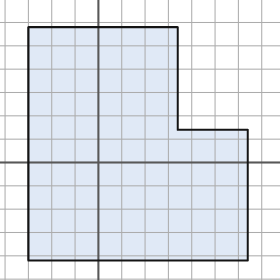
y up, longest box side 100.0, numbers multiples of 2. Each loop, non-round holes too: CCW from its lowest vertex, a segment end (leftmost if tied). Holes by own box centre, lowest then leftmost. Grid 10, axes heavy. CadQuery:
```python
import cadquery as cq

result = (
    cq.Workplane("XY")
    .moveTo(-30.0, -42.0)
    .lineTo(64.0, -42.0)
    .lineTo(64.0, 14.0)
    .lineTo(34.0, 14.0)
    .lineTo(34.0, 58.0)
    .lineTo(-30.0, 58.0)
    .close()
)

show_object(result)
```